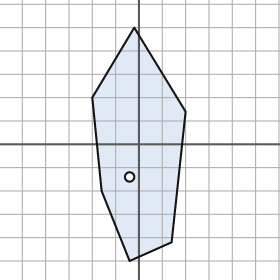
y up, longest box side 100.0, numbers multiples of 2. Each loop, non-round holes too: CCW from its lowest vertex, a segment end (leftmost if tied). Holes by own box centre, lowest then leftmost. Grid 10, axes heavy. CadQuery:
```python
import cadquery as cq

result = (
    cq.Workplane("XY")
    .moveTo(-4.0, -50.0)
    .lineTo(14.0, -42.0)
    .lineTo(20.0, 14.0)
    .lineTo(-2.0, 50.0)
    .lineTo(-20.0, 20.0)
    .lineTo(-16.0, -20.0)
    .close()
    .moveTo(-4.0, -14.0)
    .circle(2.0)
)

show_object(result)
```